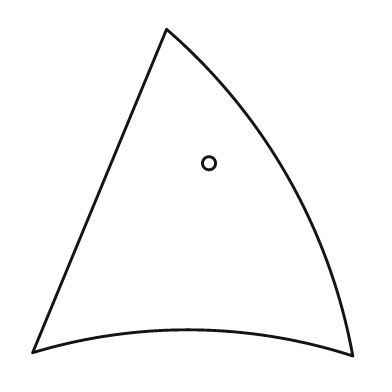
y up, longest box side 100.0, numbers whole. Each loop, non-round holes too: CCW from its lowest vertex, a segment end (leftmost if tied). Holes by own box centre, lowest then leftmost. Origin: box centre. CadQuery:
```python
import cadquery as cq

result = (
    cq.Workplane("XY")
    .moveTo(49.0, -50.0)
    .threePointArc((29.0, 5.0), (-8.0, 50.0))
    .lineTo(-49.0, -49.0)
    .threePointArc((0.0, -42.0), (49.0, -50.0))
    .close()
    .moveTo(5.0, 9.0)
    .circle(2.0)
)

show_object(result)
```